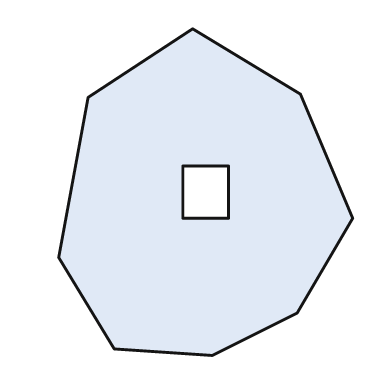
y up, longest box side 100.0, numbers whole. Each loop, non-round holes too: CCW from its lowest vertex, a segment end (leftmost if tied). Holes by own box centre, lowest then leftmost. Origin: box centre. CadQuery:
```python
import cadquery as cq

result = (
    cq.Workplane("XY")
    .moveTo(2.0, -50.0)
    .lineTo(28.0, -37.0)
    .lineTo(45.0, -8.0)
    .lineTo(29.0, 30.0)
    .lineTo(-4.0, 50.0)
    .lineTo(-36.0, 29.0)
    .lineTo(-45.0, -20.0)
    .lineTo(-28.0, -48.0)
    .close()
    .moveTo(-7.0, -8.0)
    .lineTo(7.0, -8.0)
    .lineTo(7.0, 8.0)
    .lineTo(-7.0, 8.0)
    .close()
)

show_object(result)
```